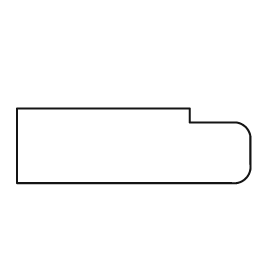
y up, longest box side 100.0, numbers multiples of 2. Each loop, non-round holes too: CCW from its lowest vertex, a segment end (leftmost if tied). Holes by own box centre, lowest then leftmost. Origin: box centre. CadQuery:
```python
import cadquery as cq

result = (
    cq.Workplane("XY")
    .moveTo(-50.0, -16.0)
    .lineTo(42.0, -16.0)
    .threePointArc((48.0, -14.0), (50.0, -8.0))
    .lineTo(50.0, 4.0)
    .threePointArc((48.0, 8.0), (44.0, 10.0))
    .lineTo(24.0, 10.0)
    .lineTo(24.0, 16.0)
    .lineTo(-50.0, 16.0)
    .close()
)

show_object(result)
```